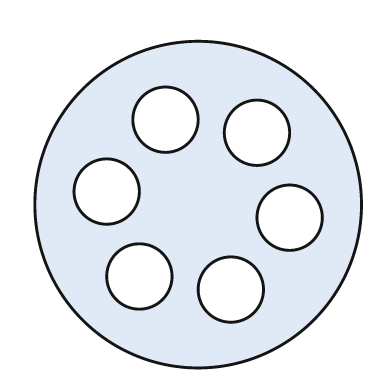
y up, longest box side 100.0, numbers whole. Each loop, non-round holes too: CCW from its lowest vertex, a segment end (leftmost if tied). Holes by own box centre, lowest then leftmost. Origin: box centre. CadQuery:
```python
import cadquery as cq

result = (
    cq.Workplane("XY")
    .moveTo(0.0, 0.0)
    .circle(50.0)
    .moveTo(10.0, -26.0)
    .circle(10.0)
    .moveTo(-18.0, -22.0)
    .circle(10.0)
    .moveTo(28.0, -4.0)
    .circle(10.0)
    .moveTo(-28.0, 4.0)
    .circle(10.0)
    .moveTo(18.0, 22.0)
    .circle(10.0)
    .moveTo(-10.0, 26.0)
    .circle(10.0)
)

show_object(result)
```